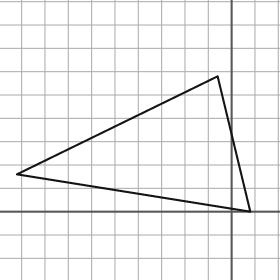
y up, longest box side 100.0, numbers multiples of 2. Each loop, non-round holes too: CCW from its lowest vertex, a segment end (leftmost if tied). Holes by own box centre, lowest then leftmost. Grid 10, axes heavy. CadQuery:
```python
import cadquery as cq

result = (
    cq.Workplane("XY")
    .moveTo(8.0, 0.0)
    .lineTo(-6.0, 58.0)
    .lineTo(-92.0, 16.0)
    .close()
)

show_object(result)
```